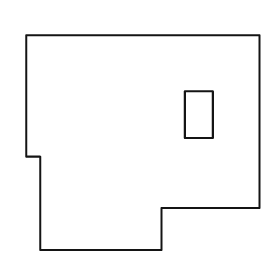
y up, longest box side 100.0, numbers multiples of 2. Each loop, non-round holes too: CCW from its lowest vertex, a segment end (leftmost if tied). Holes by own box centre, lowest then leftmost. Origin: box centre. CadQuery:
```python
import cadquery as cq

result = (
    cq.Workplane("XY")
    .moveTo(-44.0, -46.0)
    .lineTo(8.0, -46.0)
    .lineTo(8.0, -28.0)
    .lineTo(50.0, -28.0)
    .lineTo(50.0, 46.0)
    .lineTo(-50.0, 46.0)
    .lineTo(-50.0, -6.0)
    .lineTo(-44.0, -6.0)
    .close()
    .moveTo(18.0, 2.0)
    .lineTo(30.0, 2.0)
    .lineTo(30.0, 22.0)
    .lineTo(18.0, 22.0)
    .close()
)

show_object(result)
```